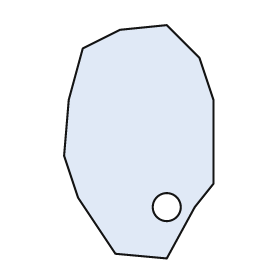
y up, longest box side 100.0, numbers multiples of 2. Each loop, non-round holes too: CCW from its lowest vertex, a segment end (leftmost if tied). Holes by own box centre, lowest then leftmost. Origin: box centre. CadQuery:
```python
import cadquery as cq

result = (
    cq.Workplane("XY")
    .moveTo(12.0, -50.0)
    .lineTo(24.0, -28.0)
    .lineTo(32.0, -18.0)
    .lineTo(32.0, 18.0)
    .lineTo(26.0, 36.0)
    .lineTo(12.0, 50.0)
    .lineTo(-8.0, 48.0)
    .lineTo(-24.0, 40.0)
    .lineTo(-30.0, 18.0)
    .lineTo(-32.0, -6.0)
    .lineTo(-26.0, -24.0)
    .lineTo(-10.0, -48.0)
    .close()
    .moveTo(12.0, -28.0)
    .circle(6.0)
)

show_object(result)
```